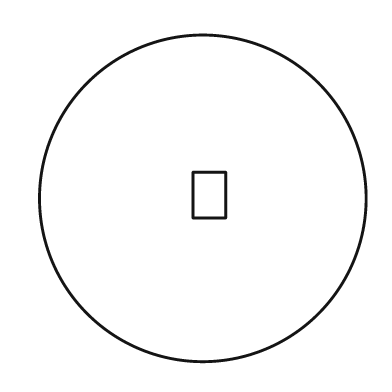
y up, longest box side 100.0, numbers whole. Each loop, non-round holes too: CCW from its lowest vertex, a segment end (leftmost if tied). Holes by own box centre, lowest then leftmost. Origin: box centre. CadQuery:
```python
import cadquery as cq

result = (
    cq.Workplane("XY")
    .moveTo(0.0, 0.0)
    .circle(50.0)
    .moveTo(-3.0, -6.0)
    .lineTo(7.0, -6.0)
    .lineTo(7.0, 8.0)
    .lineTo(-3.0, 8.0)
    .close()
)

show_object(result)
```